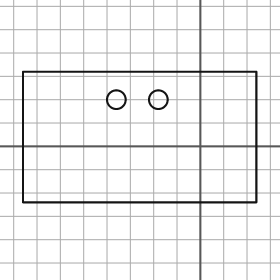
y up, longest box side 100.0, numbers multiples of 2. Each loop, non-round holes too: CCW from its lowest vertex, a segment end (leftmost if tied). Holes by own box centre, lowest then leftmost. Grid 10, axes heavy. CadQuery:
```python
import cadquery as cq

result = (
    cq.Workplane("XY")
    .moveTo(-76.0, -24.0)
    .lineTo(24.0, -24.0)
    .lineTo(24.0, 32.0)
    .lineTo(-76.0, 32.0)
    .close()
    .moveTo(-36.0, 20.0)
    .circle(4.0)
    .moveTo(-18.0, 20.0)
    .circle(4.0)
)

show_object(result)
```